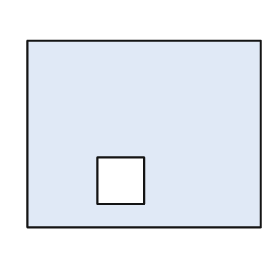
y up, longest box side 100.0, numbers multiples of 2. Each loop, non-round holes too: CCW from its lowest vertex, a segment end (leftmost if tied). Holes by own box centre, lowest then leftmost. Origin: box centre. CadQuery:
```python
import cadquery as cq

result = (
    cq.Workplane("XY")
    .moveTo(-50.0, -40.0)
    .lineTo(50.0, -40.0)
    .lineTo(50.0, 40.0)
    .lineTo(-50.0, 40.0)
    .close()
    .moveTo(-20.0, -30.0)
    .lineTo(0.0, -30.0)
    .lineTo(0.0, -10.0)
    .lineTo(-20.0, -10.0)
    .close()
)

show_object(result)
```